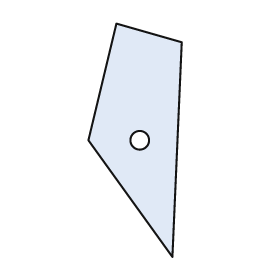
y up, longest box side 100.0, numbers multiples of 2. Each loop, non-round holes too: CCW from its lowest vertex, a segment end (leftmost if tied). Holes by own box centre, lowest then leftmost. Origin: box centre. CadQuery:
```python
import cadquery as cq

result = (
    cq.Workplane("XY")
    .moveTo(16.0, -50.0)
    .lineTo(20.0, 42.0)
    .lineTo(-8.0, 50.0)
    .lineTo(-20.0, 0.0)
    .close()
    .moveTo(2.0, 0.0)
    .circle(4.0)
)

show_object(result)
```